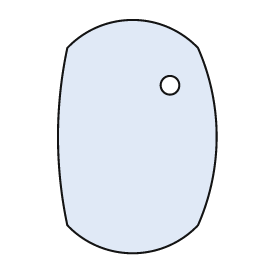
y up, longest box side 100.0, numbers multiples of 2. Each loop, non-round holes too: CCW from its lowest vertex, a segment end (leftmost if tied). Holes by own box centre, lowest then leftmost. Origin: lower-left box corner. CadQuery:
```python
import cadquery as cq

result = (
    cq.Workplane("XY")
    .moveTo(4.0, 12.0)
    .threePointArc((32.0, 0.0), (60.0, 12.0))
    .threePointArc((68.0, 50.0), (60.0, 88.0))
    .threePointArc((32.0, 100.0), (4.0, 88.0))
    .threePointArc((0.0, 50.0), (4.0, 12.0))
    .close()
    .moveTo(48.0, 72.0)
    .circle(4.0)
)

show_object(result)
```